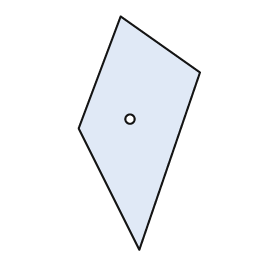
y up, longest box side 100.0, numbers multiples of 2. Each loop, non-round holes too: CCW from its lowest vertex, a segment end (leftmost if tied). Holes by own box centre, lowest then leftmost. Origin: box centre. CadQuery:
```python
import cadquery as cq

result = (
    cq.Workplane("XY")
    .moveTo(0.0, -50.0)
    .lineTo(26.0, 26.0)
    .lineTo(-8.0, 50.0)
    .lineTo(-26.0, 2.0)
    .close()
    .moveTo(-4.0, 6.0)
    .circle(2.0)
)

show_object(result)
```